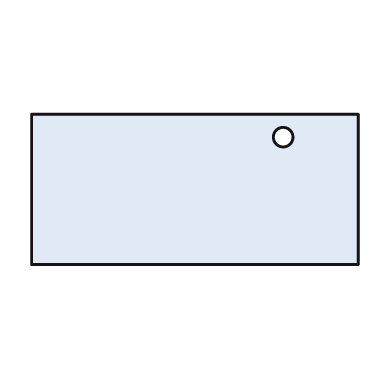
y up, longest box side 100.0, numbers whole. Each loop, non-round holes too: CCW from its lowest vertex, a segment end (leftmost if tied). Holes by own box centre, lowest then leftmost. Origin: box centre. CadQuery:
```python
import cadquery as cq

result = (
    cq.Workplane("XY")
    .moveTo(-50.0, -23.0)
    .lineTo(50.0, -23.0)
    .lineTo(50.0, 23.0)
    .lineTo(-50.0, 23.0)
    .close()
    .moveTo(27.0, 16.0)
    .circle(3.0)
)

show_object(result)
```